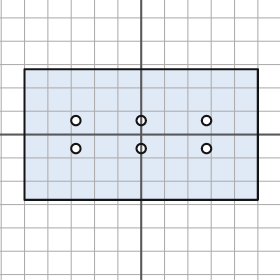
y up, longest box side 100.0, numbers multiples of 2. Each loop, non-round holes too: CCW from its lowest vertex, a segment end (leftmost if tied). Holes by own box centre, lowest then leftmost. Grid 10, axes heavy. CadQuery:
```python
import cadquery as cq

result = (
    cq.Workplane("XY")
    .moveTo(-50.0, -28.0)
    .lineTo(50.0, -28.0)
    .lineTo(50.0, 28.0)
    .lineTo(-50.0, 28.0)
    .close()
    .moveTo(-28.0, -6.0)
    .circle(2.0)
    .moveTo(0.0, -6.0)
    .circle(2.0)
    .moveTo(28.0, -6.0)
    .circle(2.0)
    .moveTo(-28.0, 6.0)
    .circle(2.0)
    .moveTo(0.0, 6.0)
    .circle(2.0)
    .moveTo(28.0, 6.0)
    .circle(2.0)
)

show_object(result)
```